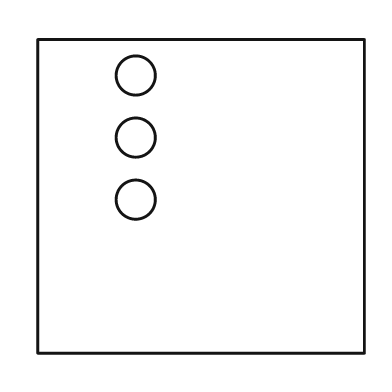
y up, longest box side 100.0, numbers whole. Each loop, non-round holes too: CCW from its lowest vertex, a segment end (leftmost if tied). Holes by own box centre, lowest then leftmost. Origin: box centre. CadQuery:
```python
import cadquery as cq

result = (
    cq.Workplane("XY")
    .moveTo(-50.0, -48.0)
    .lineTo(50.0, -48.0)
    .lineTo(50.0, 48.0)
    .lineTo(-50.0, 48.0)
    .close()
    .moveTo(-20.0, -1.0)
    .circle(6.0)
    .moveTo(-20.0, 18.0)
    .circle(6.0)
    .moveTo(-20.0, 37.0)
    .circle(6.0)
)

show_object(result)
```